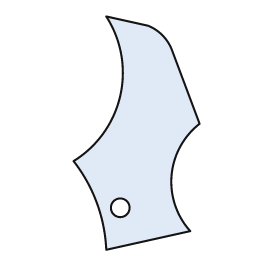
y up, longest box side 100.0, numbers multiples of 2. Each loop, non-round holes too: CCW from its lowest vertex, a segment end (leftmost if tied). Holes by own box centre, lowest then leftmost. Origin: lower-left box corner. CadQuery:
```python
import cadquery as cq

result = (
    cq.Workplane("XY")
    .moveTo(14.0, 0.0)
    .lineTo(50.0, 8.0)
    .threePointArc((42.0, 32.0), (54.0, 54.0))
    .lineTo(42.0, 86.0)
    .threePointArc((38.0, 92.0), (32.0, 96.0))
    .lineTo(14.0, 100.0)
    .threePointArc((20.0, 66.0), (0.0, 38.0))
    .threePointArc((10.0, 20.0), (14.0, 0.0))
    .close()
    .moveTo(20.0, 18.0)
    .circle(4.0)
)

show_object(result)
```